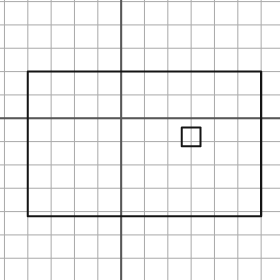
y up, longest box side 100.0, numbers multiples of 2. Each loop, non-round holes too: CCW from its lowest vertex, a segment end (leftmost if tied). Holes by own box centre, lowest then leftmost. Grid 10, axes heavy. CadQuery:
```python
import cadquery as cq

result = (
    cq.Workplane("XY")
    .moveTo(-40.0, -42.0)
    .lineTo(60.0, -42.0)
    .lineTo(60.0, 20.0)
    .lineTo(-40.0, 20.0)
    .close()
    .moveTo(26.0, -12.0)
    .lineTo(34.0, -12.0)
    .lineTo(34.0, -4.0)
    .lineTo(26.0, -4.0)
    .close()
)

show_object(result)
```